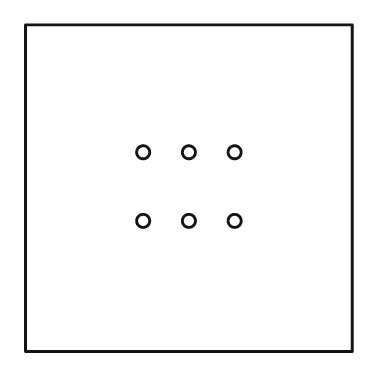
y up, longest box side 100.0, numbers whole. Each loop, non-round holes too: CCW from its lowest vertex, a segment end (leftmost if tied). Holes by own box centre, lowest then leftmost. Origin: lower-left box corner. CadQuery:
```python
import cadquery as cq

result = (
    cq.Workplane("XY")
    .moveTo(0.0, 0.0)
    .lineTo(100.0, 0.0)
    .lineTo(100.0, 100.0)
    .lineTo(0.0, 100.0)
    .close()
    .moveTo(36.0, 40.0)
    .circle(2.0)
    .moveTo(50.0, 40.0)
    .circle(2.0)
    .moveTo(64.0, 40.0)
    .circle(2.0)
    .moveTo(36.0, 61.0)
    .circle(2.0)
    .moveTo(50.0, 61.0)
    .circle(2.0)
    .moveTo(64.0, 61.0)
    .circle(2.0)
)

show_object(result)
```